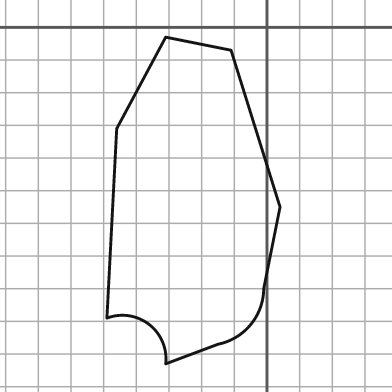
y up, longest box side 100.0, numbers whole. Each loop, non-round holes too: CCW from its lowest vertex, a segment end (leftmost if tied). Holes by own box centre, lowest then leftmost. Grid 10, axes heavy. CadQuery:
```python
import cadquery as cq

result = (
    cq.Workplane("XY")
    .moveTo(-31.0, -103.0)
    .lineTo(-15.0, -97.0)
    .threePointArc((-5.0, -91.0), (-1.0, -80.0))
    .lineTo(4.0, -55.0)
    .lineTo(-11.0, -7.0)
    .lineTo(-31.0, -3.0)
    .lineTo(-46.0, -31.0)
    .lineTo(-49.0, -89.0)
    .threePointArc((-36.0, -91.0), (-31.0, -103.0))
    .close()
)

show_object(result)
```